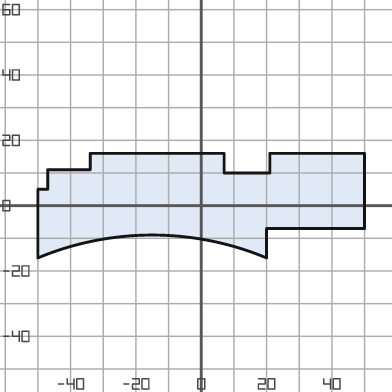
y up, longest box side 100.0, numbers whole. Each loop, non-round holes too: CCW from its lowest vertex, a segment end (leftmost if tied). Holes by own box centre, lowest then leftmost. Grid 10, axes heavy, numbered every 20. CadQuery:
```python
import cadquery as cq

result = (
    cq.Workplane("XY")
    .moveTo(-50.0, -16.0)
    .threePointArc((-15.0, -9.0), (20.0, -16.0))
    .lineTo(20.0, -7.0)
    .lineTo(50.0, -7.0)
    .lineTo(50.0, 16.0)
    .lineTo(21.0, 16.0)
    .lineTo(21.0, 10.0)
    .lineTo(7.0, 10.0)
    .lineTo(7.0, 16.0)
    .lineTo(-34.0, 16.0)
    .lineTo(-34.0, 11.0)
    .lineTo(-47.0, 11.0)
    .lineTo(-47.0, 5.0)
    .lineTo(-50.0, 5.0)
    .close()
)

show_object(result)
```